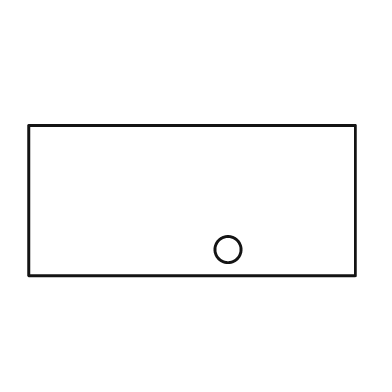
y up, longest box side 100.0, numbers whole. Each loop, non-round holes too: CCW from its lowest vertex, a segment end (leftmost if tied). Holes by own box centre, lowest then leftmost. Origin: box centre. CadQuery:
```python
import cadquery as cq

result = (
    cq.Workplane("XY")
    .moveTo(-50.0, -23.0)
    .lineTo(50.0, -23.0)
    .lineTo(50.0, 23.0)
    .lineTo(-50.0, 23.0)
    .close()
    .moveTo(11.0, -15.0)
    .circle(4.0)
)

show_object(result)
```